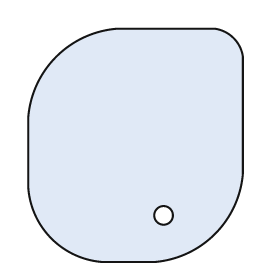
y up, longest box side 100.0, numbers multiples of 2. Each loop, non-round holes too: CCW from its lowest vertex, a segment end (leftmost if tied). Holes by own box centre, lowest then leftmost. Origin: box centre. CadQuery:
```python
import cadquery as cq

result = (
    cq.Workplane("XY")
    .moveTo(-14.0, -50.0)
    .lineTo(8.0, -50.0)
    .threePointArc((34.0, -38.0), (46.0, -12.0))
    .lineTo(46.0, 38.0)
    .threePointArc((42.0, 46.0), (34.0, 50.0))
    .lineTo(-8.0, 50.0)
    .threePointArc((-34.0, 38.0), (-46.0, 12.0))
    .lineTo(-46.0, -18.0)
    .threePointArc((-36.0, -40.0), (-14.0, -50.0))
    .close()
    .moveTo(12.0, -30.0)
    .circle(4.0)
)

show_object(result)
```